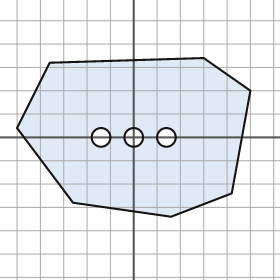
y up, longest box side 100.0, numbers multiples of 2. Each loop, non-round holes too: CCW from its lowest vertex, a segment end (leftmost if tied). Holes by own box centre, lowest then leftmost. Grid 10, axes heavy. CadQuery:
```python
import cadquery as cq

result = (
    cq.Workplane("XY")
    .moveTo(16.0, -34.0)
    .lineTo(42.0, -24.0)
    .lineTo(50.0, 20.0)
    .lineTo(30.0, 34.0)
    .lineTo(-36.0, 32.0)
    .lineTo(-50.0, 4.0)
    .lineTo(-26.0, -28.0)
    .close()
    .moveTo(-14.0, 0.0)
    .circle(4.0)
    .moveTo(0.0, 0.0)
    .circle(4.0)
    .moveTo(14.0, 0.0)
    .circle(4.0)
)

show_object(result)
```